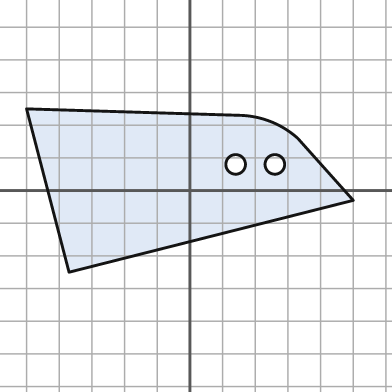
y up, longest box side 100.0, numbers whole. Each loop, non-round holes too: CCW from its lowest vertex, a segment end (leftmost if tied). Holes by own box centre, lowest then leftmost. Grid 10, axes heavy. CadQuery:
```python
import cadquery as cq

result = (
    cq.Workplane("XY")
    .moveTo(-37.0, -25.0)
    .lineTo(50.0, -3.0)
    .lineTo(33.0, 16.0)
    .threePointArc((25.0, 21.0), (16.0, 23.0))
    .lineTo(-50.0, 25.0)
    .close()
    .moveTo(14.0, 8.0)
    .circle(3.0)
    .moveTo(26.0, 8.0)
    .circle(3.0)
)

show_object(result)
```